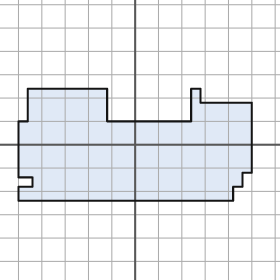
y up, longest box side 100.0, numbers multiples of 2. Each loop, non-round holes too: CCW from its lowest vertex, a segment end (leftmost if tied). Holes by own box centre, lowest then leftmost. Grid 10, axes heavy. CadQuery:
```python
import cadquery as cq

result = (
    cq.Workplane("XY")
    .moveTo(-50.0, -24.0)
    .lineTo(42.0, -24.0)
    .lineTo(42.0, -18.0)
    .lineTo(46.0, -18.0)
    .lineTo(46.0, -12.0)
    .lineTo(50.0, -12.0)
    .lineTo(50.0, 18.0)
    .lineTo(28.0, 18.0)
    .lineTo(28.0, 24.0)
    .lineTo(24.0, 24.0)
    .lineTo(24.0, 10.0)
    .lineTo(-12.0, 10.0)
    .lineTo(-12.0, 24.0)
    .lineTo(-46.0, 24.0)
    .lineTo(-46.0, 10.0)
    .lineTo(-50.0, 10.0)
    .lineTo(-50.0, -14.0)
    .lineTo(-44.0, -14.0)
    .lineTo(-44.0, -18.0)
    .lineTo(-50.0, -18.0)
    .close()
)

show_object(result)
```